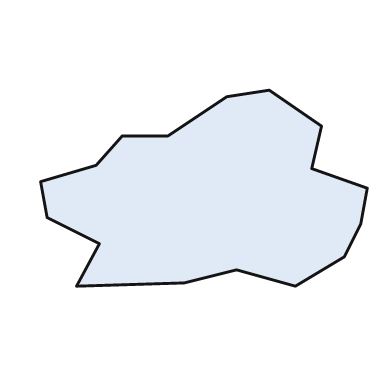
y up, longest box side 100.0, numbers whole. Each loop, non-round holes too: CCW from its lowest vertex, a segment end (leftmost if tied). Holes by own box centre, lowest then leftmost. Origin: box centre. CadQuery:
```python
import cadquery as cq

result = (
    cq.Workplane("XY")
    .moveTo(-39.0, -30.0)
    .lineTo(-6.0, -29.0)
    .lineTo(10.0, -25.0)
    .lineTo(28.0, -30.0)
    .lineTo(43.0, -21.0)
    .lineTo(48.0, -11.0)
    .lineTo(50.0, 0.0)
    .lineTo(33.0, 6.0)
    .lineTo(36.0, 19.0)
    .lineTo(20.0, 30.0)
    .lineTo(7.0, 28.0)
    .lineTo(-11.0, 16.0)
    .lineTo(-25.0, 16.0)
    .lineTo(-33.0, 7.0)
    .lineTo(-50.0, 2.0)
    .lineTo(-48.0, -9.0)
    .lineTo(-32.0, -17.0)
    .close()
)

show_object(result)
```